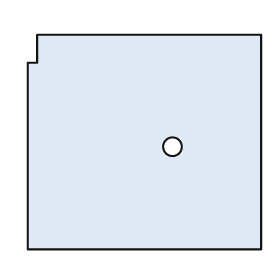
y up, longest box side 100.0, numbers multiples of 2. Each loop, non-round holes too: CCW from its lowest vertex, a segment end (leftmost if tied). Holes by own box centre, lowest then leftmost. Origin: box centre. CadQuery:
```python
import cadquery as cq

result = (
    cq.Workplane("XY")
    .moveTo(-50.0, -46.0)
    .lineTo(50.0, -46.0)
    .lineTo(50.0, 46.0)
    .lineTo(-46.0, 46.0)
    .lineTo(-46.0, 34.0)
    .lineTo(-50.0, 34.0)
    .close()
    .moveTo(12.0, -2.0)
    .circle(4.0)
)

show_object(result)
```